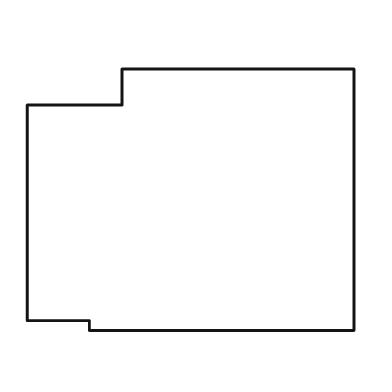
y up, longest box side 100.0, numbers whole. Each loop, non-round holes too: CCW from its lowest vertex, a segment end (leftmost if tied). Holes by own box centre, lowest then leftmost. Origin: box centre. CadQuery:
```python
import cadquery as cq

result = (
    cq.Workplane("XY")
    .moveTo(-31.0, -40.0)
    .lineTo(50.0, -40.0)
    .lineTo(50.0, 40.0)
    .lineTo(-21.0, 40.0)
    .lineTo(-21.0, 29.0)
    .lineTo(-50.0, 29.0)
    .lineTo(-50.0, -37.0)
    .lineTo(-31.0, -37.0)
    .close()
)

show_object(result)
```